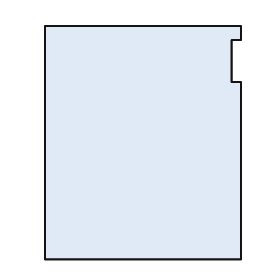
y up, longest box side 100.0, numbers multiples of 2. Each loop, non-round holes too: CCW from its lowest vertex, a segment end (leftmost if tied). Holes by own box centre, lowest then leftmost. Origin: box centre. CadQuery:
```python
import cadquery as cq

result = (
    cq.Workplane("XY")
    .moveTo(-42.0, -50.0)
    .lineTo(42.0, -50.0)
    .lineTo(42.0, 26.0)
    .lineTo(38.0, 26.0)
    .lineTo(38.0, 44.0)
    .lineTo(42.0, 44.0)
    .lineTo(42.0, 50.0)
    .lineTo(-42.0, 50.0)
    .close()
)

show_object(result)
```